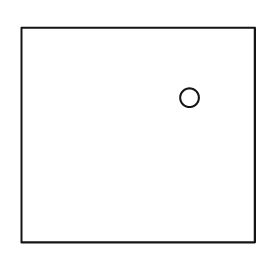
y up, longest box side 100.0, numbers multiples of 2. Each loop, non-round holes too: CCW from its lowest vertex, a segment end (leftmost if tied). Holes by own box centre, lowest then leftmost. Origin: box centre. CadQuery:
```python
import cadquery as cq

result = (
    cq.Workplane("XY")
    .moveTo(-50.0, -46.0)
    .lineTo(50.0, -46.0)
    .lineTo(50.0, 46.0)
    .lineTo(-50.0, 46.0)
    .close()
    .moveTo(22.0, 16.0)
    .circle(4.0)
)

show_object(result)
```